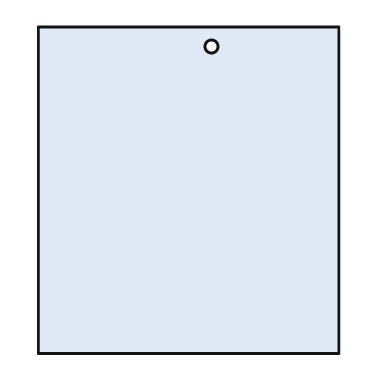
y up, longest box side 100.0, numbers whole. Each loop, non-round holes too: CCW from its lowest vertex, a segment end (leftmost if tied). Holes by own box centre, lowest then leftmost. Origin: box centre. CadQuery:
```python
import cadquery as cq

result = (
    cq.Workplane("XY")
    .moveTo(-46.0, -50.0)
    .lineTo(46.0, -50.0)
    .lineTo(46.0, 50.0)
    .lineTo(-46.0, 50.0)
    .close()
    .moveTo(7.0, 44.0)
    .circle(2.0)
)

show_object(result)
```